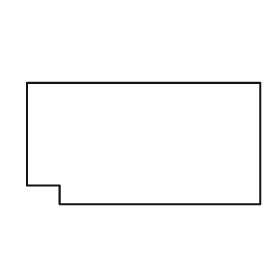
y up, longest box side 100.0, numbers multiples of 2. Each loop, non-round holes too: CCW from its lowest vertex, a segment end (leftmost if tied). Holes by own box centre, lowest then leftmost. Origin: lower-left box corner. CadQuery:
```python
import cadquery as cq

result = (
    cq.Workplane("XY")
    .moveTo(14.0, 0.0)
    .lineTo(100.0, 0.0)
    .lineTo(100.0, 52.0)
    .lineTo(0.0, 52.0)
    .lineTo(0.0, 8.0)
    .lineTo(14.0, 8.0)
    .close()
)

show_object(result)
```